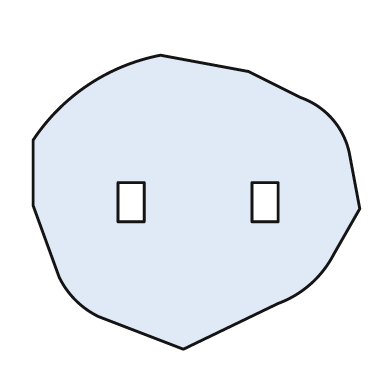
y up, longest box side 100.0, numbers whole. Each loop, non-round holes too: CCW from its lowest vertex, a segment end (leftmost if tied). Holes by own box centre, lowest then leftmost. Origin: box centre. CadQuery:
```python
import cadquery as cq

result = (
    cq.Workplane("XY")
    .moveTo(-4.0, -45.0)
    .lineTo(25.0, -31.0)
    .threePointArc((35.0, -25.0), (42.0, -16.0))
    .lineTo(50.0, -2.0)
    .lineTo(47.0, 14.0)
    .threePointArc((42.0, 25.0), (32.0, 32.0))
    .lineTo(16.0, 40.0)
    .lineTo(-11.0, 45.0)
    .threePointArc((-33.0, 36.0), (-50.0, 19.0))
    .lineTo(-50.0, -1.0)
    .lineTo(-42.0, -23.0)
    .threePointArc((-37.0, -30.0), (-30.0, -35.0))
    .close()
    .moveTo(-24.0, -6.0)
    .lineTo(-16.0, -6.0)
    .lineTo(-16.0, 6.0)
    .lineTo(-24.0, 6.0)
    .close()
    .moveTo(17.0, -6.0)
    .lineTo(25.0, -6.0)
    .lineTo(25.0, 6.0)
    .lineTo(17.0, 6.0)
    .close()
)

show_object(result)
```